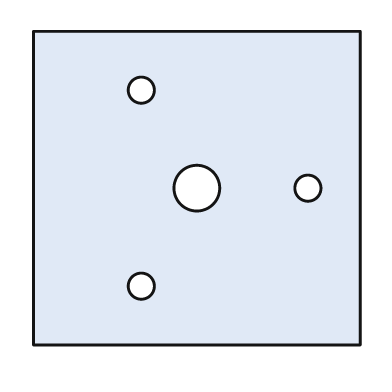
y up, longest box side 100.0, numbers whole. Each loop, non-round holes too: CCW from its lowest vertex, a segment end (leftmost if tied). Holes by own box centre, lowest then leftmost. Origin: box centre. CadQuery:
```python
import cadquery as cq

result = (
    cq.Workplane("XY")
    .moveTo(-50.0, -48.0)
    .lineTo(50.0, -48.0)
    .lineTo(50.0, 48.0)
    .lineTo(-50.0, 48.0)
    .close()
    .moveTo(-17.0, -30.0)
    .circle(4.0)
    .moveTo(0.0, 0.0)
    .circle(7.0)
    .moveTo(34.0, 0.0)
    .circle(4.0)
    .moveTo(-17.0, 30.0)
    .circle(4.0)
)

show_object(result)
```